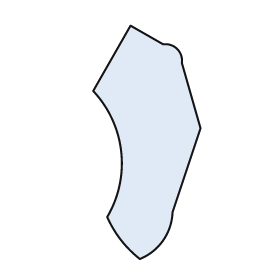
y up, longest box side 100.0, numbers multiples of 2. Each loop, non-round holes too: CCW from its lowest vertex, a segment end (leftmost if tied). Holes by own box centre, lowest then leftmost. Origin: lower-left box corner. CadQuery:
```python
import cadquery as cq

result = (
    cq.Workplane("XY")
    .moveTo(20.0, 0.0)
    .threePointArc((30.0, 8.0), (34.0, 20.0))
    .lineTo(46.0, 56.0)
    .lineTo(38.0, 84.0)
    .threePointArc((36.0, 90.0), (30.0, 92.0))
    .lineTo(16.0, 100.0)
    .lineTo(0.0, 72.0)
    .threePointArc((12.0, 46.0), (6.0, 18.0))
    .threePointArc((12.0, 8.0), (20.0, 0.0))
    .close()
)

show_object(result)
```